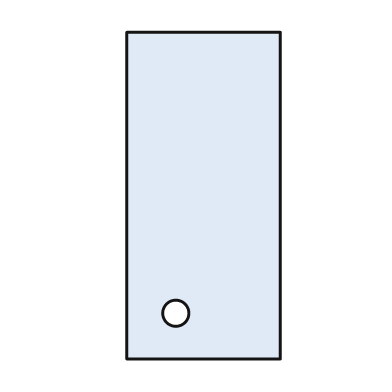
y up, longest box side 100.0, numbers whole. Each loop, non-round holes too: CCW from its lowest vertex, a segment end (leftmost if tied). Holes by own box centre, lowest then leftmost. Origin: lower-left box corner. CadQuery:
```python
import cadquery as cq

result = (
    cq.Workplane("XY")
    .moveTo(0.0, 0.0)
    .lineTo(47.0, 0.0)
    .lineTo(47.0, 100.0)
    .lineTo(0.0, 100.0)
    .close()
    .moveTo(15.0, 14.0)
    .circle(4.0)
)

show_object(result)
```